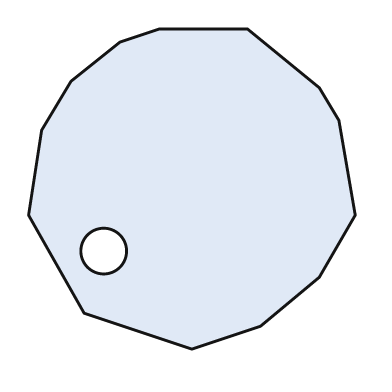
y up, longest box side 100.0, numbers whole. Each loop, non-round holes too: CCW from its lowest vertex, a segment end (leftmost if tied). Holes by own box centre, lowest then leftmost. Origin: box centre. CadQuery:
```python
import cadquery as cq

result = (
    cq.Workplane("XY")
    .moveTo(0.0, -49.0)
    .lineTo(21.0, -42.0)
    .lineTo(39.0, -27.0)
    .lineTo(50.0, -8.0)
    .lineTo(45.0, 21.0)
    .lineTo(39.0, 31.0)
    .lineTo(17.0, 49.0)
    .lineTo(-10.0, 49.0)
    .lineTo(-22.0, 45.0)
    .lineTo(-37.0, 33.0)
    .lineTo(-46.0, 18.0)
    .lineTo(-50.0, -8.0)
    .lineTo(-33.0, -38.0)
    .close()
    .moveTo(-27.0, -19.0)
    .circle(7.0)
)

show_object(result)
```